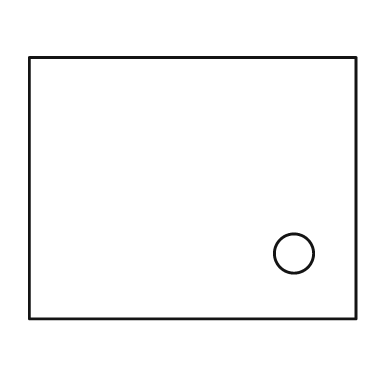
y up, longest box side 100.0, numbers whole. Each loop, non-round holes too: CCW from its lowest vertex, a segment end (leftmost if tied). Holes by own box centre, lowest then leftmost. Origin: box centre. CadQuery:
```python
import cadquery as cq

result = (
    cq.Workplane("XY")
    .moveTo(-50.0, -40.0)
    .lineTo(50.0, -40.0)
    .lineTo(50.0, 40.0)
    .lineTo(-50.0, 40.0)
    .close()
    .moveTo(31.0, -20.0)
    .circle(6.0)
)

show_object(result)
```